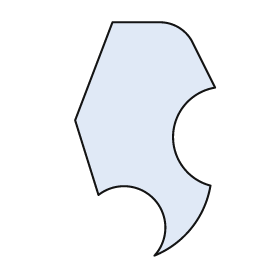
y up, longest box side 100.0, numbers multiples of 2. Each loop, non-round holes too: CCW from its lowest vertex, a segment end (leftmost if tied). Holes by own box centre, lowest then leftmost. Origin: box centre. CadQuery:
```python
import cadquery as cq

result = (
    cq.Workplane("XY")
    .moveTo(4.0, -50.0)
    .threePointArc((20.0, -38.0), (28.0, -20.0))
    .threePointArc((12.0, 2.0), (30.0, 22.0))
    .lineTo(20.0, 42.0)
    .threePointArc((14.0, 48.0), (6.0, 50.0))
    .lineTo(-14.0, 50.0)
    .lineTo(-30.0, 8.0)
    .lineTo(-20.0, -24.0)
    .threePointArc((4.0, -26.0), (4.0, -50.0))
    .close()
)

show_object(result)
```